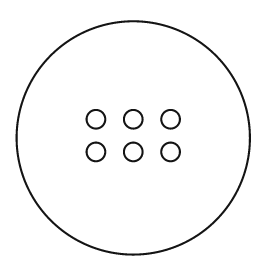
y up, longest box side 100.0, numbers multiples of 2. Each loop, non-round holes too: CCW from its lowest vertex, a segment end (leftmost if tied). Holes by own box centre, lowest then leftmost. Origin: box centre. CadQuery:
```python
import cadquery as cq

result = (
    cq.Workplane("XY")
    .moveTo(0.0, 0.0)
    .circle(50.0)
    .moveTo(-16.0, -6.0)
    .circle(4.0)
    .moveTo(0.0, -6.0)
    .circle(4.0)
    .moveTo(16.0, -6.0)
    .circle(4.0)
    .moveTo(-16.0, 8.0)
    .circle(4.0)
    .moveTo(0.0, 8.0)
    .circle(4.0)
    .moveTo(16.0, 8.0)
    .circle(4.0)
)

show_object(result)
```